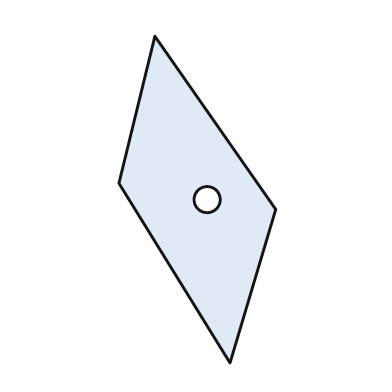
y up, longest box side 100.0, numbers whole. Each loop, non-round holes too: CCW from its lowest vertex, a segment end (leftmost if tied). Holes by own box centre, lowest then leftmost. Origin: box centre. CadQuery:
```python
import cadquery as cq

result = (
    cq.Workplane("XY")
    .moveTo(10.0, -50.0)
    .lineTo(24.0, -3.0)
    .lineTo(-13.0, 50.0)
    .lineTo(-24.0, 5.0)
    .close()
    .moveTo(3.0, 0.0)
    .circle(4.0)
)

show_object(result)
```